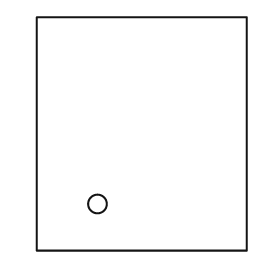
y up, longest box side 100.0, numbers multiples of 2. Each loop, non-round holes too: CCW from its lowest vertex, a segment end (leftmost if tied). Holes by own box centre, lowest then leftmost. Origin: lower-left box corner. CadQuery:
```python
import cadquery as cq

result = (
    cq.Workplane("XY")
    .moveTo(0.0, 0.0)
    .lineTo(90.0, 0.0)
    .lineTo(90.0, 100.0)
    .lineTo(0.0, 100.0)
    .close()
    .moveTo(26.0, 20.0)
    .circle(4.0)
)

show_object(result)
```